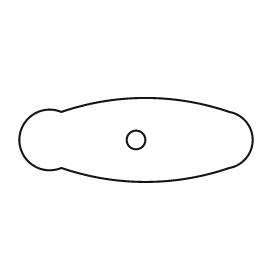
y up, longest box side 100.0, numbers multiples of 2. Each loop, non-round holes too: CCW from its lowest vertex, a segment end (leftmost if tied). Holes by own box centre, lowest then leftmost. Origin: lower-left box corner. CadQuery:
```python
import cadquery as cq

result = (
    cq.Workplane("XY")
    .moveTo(18.0, 6.0)
    .threePointArc((54.0, 0.0), (90.0, 6.0))
    .threePointArc((100.0, 18.0), (90.0, 30.0))
    .threePointArc((54.0, 36.0), (18.0, 30.0))
    .threePointArc((0.0, 18.0), (18.0, 6.0))
    .close()
    .moveTo(50.0, 18.0)
    .circle(4.0)
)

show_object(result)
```